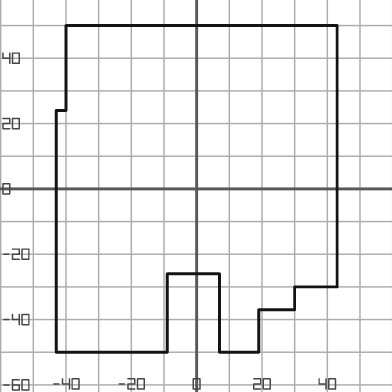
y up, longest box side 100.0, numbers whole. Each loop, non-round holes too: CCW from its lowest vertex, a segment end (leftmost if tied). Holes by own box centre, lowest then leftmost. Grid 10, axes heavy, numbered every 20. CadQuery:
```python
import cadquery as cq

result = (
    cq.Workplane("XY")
    .moveTo(-43.0, -50.0)
    .lineTo(-9.0, -50.0)
    .lineTo(-9.0, -26.0)
    .lineTo(7.0, -26.0)
    .lineTo(7.0, -50.0)
    .lineTo(19.0, -50.0)
    .lineTo(19.0, -37.0)
    .lineTo(30.0, -37.0)
    .lineTo(30.0, -30.0)
    .lineTo(43.0, -30.0)
    .lineTo(43.0, 50.0)
    .lineTo(-40.0, 50.0)
    .lineTo(-40.0, 24.0)
    .lineTo(-43.0, 24.0)
    .close()
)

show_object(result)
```